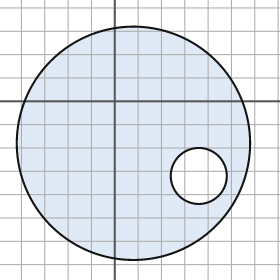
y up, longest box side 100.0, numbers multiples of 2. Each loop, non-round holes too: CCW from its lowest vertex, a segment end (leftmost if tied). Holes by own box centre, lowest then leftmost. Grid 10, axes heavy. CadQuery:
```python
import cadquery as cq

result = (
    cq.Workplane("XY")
    .moveTo(8.0, -18.0)
    .circle(50.0)
    .moveTo(36.0, -32.0)
    .circle(12.0)
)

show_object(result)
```